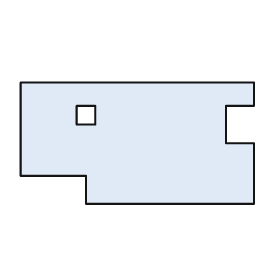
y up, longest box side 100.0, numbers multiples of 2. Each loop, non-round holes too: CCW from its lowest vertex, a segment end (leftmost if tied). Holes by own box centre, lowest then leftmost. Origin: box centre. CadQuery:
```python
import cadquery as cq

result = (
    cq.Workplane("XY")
    .moveTo(-22.0, -26.0)
    .lineTo(50.0, -26.0)
    .lineTo(50.0, 0.0)
    .lineTo(38.0, 0.0)
    .lineTo(38.0, 16.0)
    .lineTo(50.0, 16.0)
    .lineTo(50.0, 26.0)
    .lineTo(-50.0, 26.0)
    .lineTo(-50.0, -14.0)
    .lineTo(-22.0, -14.0)
    .close()
    .moveTo(-26.0, 8.0)
    .lineTo(-18.0, 8.0)
    .lineTo(-18.0, 16.0)
    .lineTo(-26.0, 16.0)
    .close()
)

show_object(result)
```